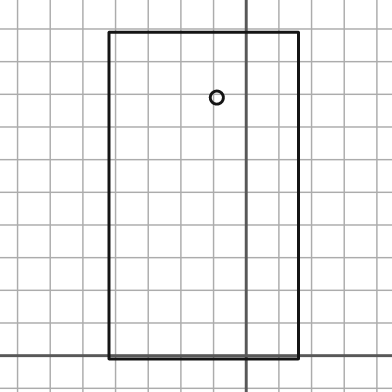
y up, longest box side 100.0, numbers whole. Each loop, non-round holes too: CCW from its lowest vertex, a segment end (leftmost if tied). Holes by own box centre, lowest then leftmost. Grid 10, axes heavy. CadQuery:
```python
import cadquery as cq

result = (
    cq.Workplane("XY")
    .moveTo(-42.0, -1.0)
    .lineTo(16.0, -1.0)
    .lineTo(16.0, 99.0)
    .lineTo(-42.0, 99.0)
    .close()
    .moveTo(-9.0, 79.0)
    .circle(2.0)
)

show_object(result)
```